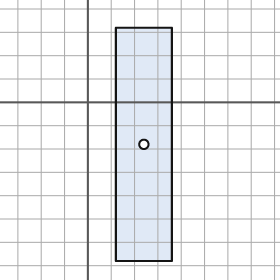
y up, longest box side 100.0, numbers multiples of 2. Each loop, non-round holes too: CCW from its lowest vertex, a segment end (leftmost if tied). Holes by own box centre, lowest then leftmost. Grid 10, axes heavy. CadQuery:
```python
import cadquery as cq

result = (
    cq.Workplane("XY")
    .moveTo(12.0, -68.0)
    .lineTo(36.0, -68.0)
    .lineTo(36.0, 32.0)
    .lineTo(12.0, 32.0)
    .close()
    .moveTo(24.0, -18.0)
    .circle(2.0)
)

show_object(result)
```